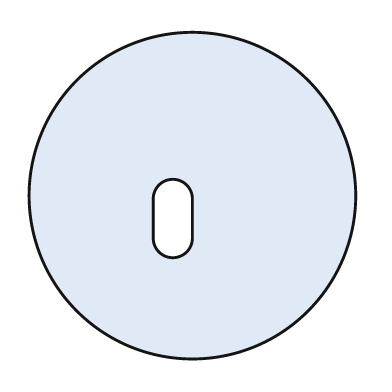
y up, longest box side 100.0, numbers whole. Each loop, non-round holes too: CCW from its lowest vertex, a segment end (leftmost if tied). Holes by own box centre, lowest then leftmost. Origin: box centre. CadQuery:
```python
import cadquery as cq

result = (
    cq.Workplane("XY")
    .moveTo(0.0, 0.0)
    .circle(50.0)
    .moveTo(-12.0, -13.0)
    .threePointArc((-6.0, -19.0), (0.0, -13.0))
    .lineTo(0.0, -1.0)
    .threePointArc((-6.0, 5.0), (-12.0, -1.0))
    .close()
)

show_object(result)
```